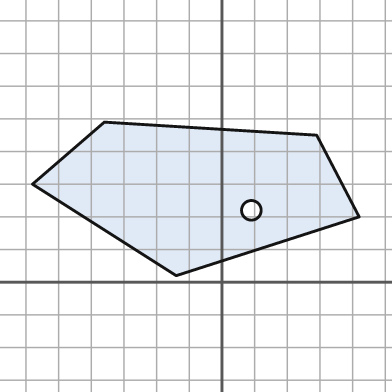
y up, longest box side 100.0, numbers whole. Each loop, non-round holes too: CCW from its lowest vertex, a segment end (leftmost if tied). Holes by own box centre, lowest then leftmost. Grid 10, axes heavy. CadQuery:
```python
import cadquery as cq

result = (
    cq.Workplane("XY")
    .moveTo(-14.0, 2.0)
    .lineTo(42.0, 20.0)
    .lineTo(29.0, 45.0)
    .lineTo(-36.0, 49.0)
    .lineTo(-58.0, 30.0)
    .close()
    .moveTo(9.0, 22.0)
    .circle(3.0)
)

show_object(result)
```